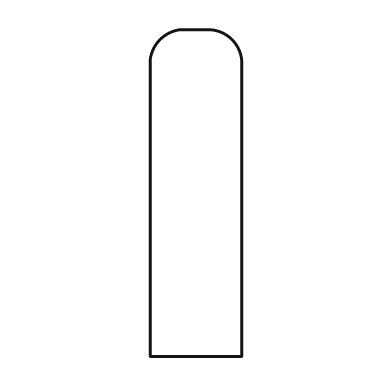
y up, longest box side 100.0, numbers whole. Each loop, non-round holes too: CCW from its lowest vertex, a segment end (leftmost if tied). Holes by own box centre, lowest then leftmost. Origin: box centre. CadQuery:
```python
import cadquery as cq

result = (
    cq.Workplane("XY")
    .moveTo(-14.0, -50.0)
    .lineTo(14.0, -50.0)
    .lineTo(14.0, 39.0)
    .threePointArc((11.0, 47.0), (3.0, 50.0))
    .lineTo(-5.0, 50.0)
    .threePointArc((-11.0, 47.0), (-14.0, 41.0))
    .close()
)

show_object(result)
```